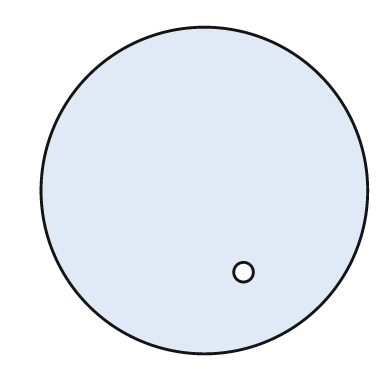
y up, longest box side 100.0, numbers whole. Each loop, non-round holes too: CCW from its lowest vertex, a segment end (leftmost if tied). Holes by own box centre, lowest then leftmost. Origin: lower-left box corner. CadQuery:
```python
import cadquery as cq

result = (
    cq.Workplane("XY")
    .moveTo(50.0, 50.0)
    .circle(50.0)
    .moveTo(62.0, 25.0)
    .circle(3.0)
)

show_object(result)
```